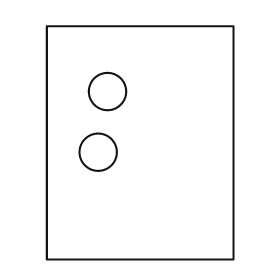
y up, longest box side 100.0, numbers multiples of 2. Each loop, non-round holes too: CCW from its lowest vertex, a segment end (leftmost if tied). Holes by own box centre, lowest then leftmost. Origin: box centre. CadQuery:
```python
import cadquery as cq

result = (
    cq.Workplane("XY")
    .moveTo(-40.0, -50.0)
    .lineTo(40.0, -50.0)
    .lineTo(40.0, 50.0)
    .lineTo(-40.0, 50.0)
    .close()
    .moveTo(-18.0, -4.0)
    .circle(8.0)
    .moveTo(-14.0, 22.0)
    .circle(8.0)
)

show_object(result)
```